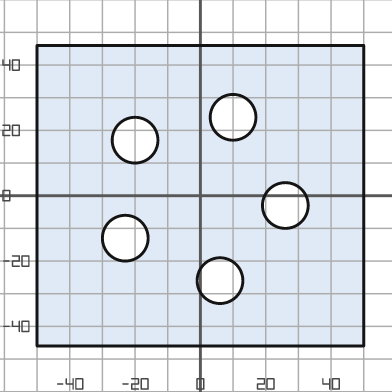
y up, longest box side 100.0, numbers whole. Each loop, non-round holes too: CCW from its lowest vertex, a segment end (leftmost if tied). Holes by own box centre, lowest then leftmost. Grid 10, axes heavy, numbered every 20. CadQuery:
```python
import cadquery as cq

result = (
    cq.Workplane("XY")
    .moveTo(-50.0, -46.0)
    .lineTo(50.0, -46.0)
    .lineTo(50.0, 46.0)
    .lineTo(-50.0, 46.0)
    .close()
    .moveTo(6.0, -26.0)
    .circle(7.0)
    .moveTo(-23.0, -13.0)
    .circle(7.0)
    .moveTo(26.0, -3.0)
    .circle(7.0)
    .moveTo(-20.0, 17.0)
    .circle(7.0)
    .moveTo(10.0, 24.0)
    .circle(7.0)
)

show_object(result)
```